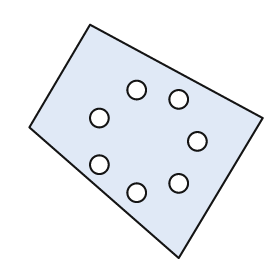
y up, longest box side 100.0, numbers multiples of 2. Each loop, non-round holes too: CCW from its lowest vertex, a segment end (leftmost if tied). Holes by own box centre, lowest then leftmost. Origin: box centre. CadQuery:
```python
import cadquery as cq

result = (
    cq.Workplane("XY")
    .moveTo(14.0, -50.0)
    .lineTo(50.0, 10.0)
    .lineTo(-24.0, 50.0)
    .lineTo(-50.0, 6.0)
    .close()
    .moveTo(-4.0, -22.0)
    .circle(4.0)
    .moveTo(14.0, -18.0)
    .circle(4.0)
    .moveTo(-20.0, -10.0)
    .circle(4.0)
    .moveTo(22.0, 0.0)
    .circle(4.0)
    .moveTo(-20.0, 10.0)
    .circle(4.0)
    .moveTo(14.0, 18.0)
    .circle(4.0)
    .moveTo(-4.0, 22.0)
    .circle(4.0)
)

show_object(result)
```